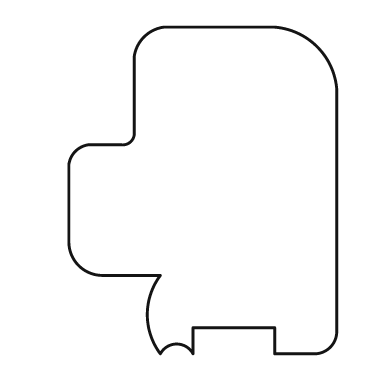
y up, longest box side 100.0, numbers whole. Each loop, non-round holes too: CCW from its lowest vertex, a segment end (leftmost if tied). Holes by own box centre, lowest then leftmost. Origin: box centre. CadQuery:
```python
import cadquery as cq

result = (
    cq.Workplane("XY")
    .moveTo(-13.0, -50.0)
    .threePointArc((-8.0, -47.0), (-3.0, -50.0))
    .lineTo(-3.0, -42.0)
    .lineTo(22.0, -42.0)
    .lineTo(22.0, -50.0)
    .lineTo(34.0, -50.0)
    .threePointArc((39.0, -48.0), (41.0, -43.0))
    .lineTo(41.0, 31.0)
    .threePointArc((35.0, 44.0), (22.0, 50.0))
    .lineTo(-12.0, 50.0)
    .threePointArc((-18.0, 47.0), (-21.0, 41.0))
    .lineTo(-21.0, 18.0)
    .threePointArc((-22.0, 15.0), (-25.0, 14.0))
    .lineTo(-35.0, 14.0)
    .threePointArc((-39.0, 12.0), (-41.0, 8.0))
    .lineTo(-41.0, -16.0)
    .threePointArc((-38.0, -23.0), (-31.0, -26.0))
    .lineTo(-13.0, -26.0)
    .threePointArc((-17.0, -38.0), (-13.0, -50.0))
    .close()
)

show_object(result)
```